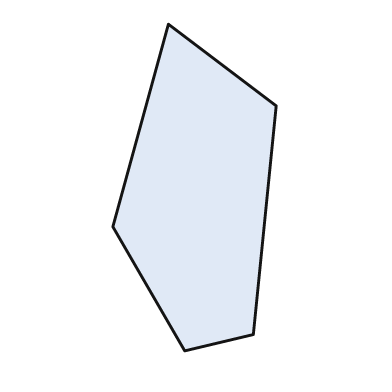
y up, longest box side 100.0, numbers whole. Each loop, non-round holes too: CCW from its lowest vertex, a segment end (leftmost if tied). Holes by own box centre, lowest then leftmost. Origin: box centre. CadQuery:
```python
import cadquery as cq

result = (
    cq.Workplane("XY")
    .moveTo(-3.0, -50.0)
    .lineTo(18.0, -45.0)
    .lineTo(25.0, 25.0)
    .lineTo(-8.0, 50.0)
    .lineTo(-25.0, -12.0)
    .close()
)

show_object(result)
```